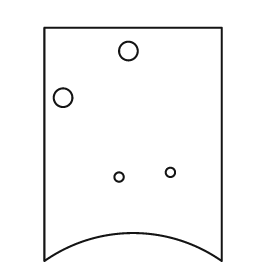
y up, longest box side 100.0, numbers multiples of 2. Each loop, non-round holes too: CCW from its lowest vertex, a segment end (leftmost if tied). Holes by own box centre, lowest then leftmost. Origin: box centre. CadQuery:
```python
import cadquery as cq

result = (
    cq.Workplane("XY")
    .moveTo(-38.0, -50.0)
    .threePointArc((0.0, -38.0), (38.0, -50.0))
    .lineTo(38.0, 50.0)
    .lineTo(-38.0, 50.0)
    .close()
    .moveTo(-6.0, -14.0)
    .circle(2.0)
    .moveTo(16.0, -12.0)
    .circle(2.0)
    .moveTo(-30.0, 20.0)
    .circle(4.0)
    .moveTo(-2.0, 40.0)
    .circle(4.0)
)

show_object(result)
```